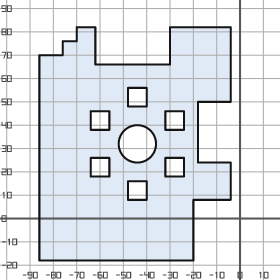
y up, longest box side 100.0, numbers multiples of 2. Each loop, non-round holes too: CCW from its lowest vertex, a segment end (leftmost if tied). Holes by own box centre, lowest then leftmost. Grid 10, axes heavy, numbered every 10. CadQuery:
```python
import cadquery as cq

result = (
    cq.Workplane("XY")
    .moveTo(-86.0, -18.0)
    .lineTo(-20.0, -18.0)
    .lineTo(-20.0, 8.0)
    .lineTo(-4.0, 8.0)
    .lineTo(-4.0, 24.0)
    .lineTo(-18.0, 24.0)
    .lineTo(-18.0, 50.0)
    .lineTo(-4.0, 50.0)
    .lineTo(-4.0, 82.0)
    .lineTo(-30.0, 82.0)
    .lineTo(-30.0, 66.0)
    .lineTo(-62.0, 66.0)
    .lineTo(-62.0, 82.0)
    .lineTo(-70.0, 82.0)
    .lineTo(-70.0, 76.0)
    .lineTo(-76.0, 76.0)
    .lineTo(-76.0, 70.0)
    .lineTo(-86.0, 70.0)
    .close()
    .moveTo(-48.0, 8.0)
    .lineTo(-40.0, 8.0)
    .lineTo(-40.0, 16.0)
    .lineTo(-48.0, 16.0)
    .close()
    .moveTo(-64.0, 18.0)
    .lineTo(-56.0, 18.0)
    .lineTo(-56.0, 26.0)
    .lineTo(-64.0, 26.0)
    .close()
    .moveTo(-32.0, 18.0)
    .lineTo(-24.0, 18.0)
    .lineTo(-24.0, 26.0)
    .lineTo(-32.0, 26.0)
    .close()
    .moveTo(-44.0, 32.0)
    .circle(8.0)
    .moveTo(-64.0, 38.0)
    .lineTo(-56.0, 38.0)
    .lineTo(-56.0, 46.0)
    .lineTo(-64.0, 46.0)
    .close()
    .moveTo(-32.0, 38.0)
    .lineTo(-24.0, 38.0)
    .lineTo(-24.0, 46.0)
    .lineTo(-32.0, 46.0)
    .close()
    .moveTo(-48.0, 48.0)
    .lineTo(-40.0, 48.0)
    .lineTo(-40.0, 56.0)
    .lineTo(-48.0, 56.0)
    .close()
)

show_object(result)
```